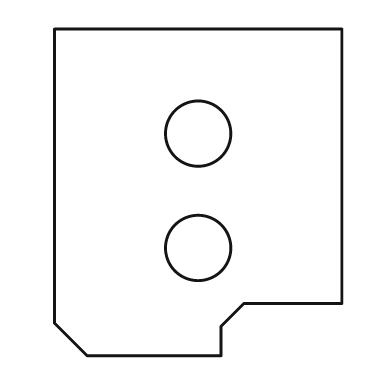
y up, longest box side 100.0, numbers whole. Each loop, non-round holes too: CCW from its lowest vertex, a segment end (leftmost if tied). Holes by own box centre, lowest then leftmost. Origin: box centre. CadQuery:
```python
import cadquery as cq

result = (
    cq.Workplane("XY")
    .moveTo(-34.0, -50.0)
    .lineTo(7.0, -50.0)
    .lineTo(7.0, -41.0)
    .lineTo(14.0, -34.0)
    .lineTo(44.0, -34.0)
    .lineTo(44.0, 50.0)
    .lineTo(-44.0, 50.0)
    .lineTo(-44.0, -40.0)
    .close()
    .moveTo(0.0, -17.0)
    .circle(10.0)
    .moveTo(0.0, 18.0)
    .circle(10.0)
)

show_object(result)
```